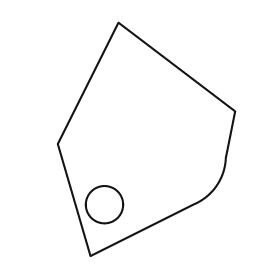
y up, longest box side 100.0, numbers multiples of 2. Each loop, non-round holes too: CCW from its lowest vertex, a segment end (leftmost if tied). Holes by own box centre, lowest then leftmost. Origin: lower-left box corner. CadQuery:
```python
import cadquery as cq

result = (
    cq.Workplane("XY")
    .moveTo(14.0, 0.0)
    .lineTo(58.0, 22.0)
    .threePointArc((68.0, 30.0), (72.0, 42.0))
    .lineTo(76.0, 62.0)
    .lineTo(26.0, 100.0)
    .lineTo(0.0, 48.0)
    .close()
    .moveTo(20.0, 22.0)
    .circle(8.0)
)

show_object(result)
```